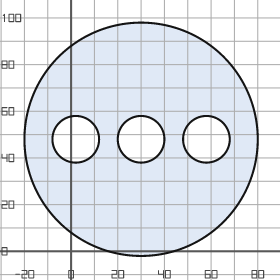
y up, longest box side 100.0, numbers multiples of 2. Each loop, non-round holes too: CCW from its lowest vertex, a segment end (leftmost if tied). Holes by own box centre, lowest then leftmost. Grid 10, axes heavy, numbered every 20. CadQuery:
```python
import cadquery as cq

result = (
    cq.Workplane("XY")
    .moveTo(30.0, 48.0)
    .circle(50.0)
    .moveTo(2.0, 48.0)
    .circle(10.0)
    .moveTo(30.0, 48.0)
    .circle(10.0)
    .moveTo(58.0, 48.0)
    .circle(10.0)
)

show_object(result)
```